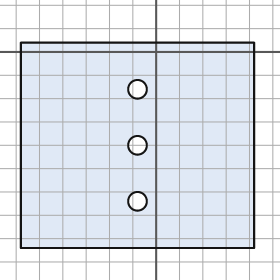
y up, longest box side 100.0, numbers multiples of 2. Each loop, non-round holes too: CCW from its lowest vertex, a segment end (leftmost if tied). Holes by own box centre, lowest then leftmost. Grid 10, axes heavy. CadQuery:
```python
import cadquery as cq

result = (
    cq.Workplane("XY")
    .moveTo(-58.0, -84.0)
    .lineTo(42.0, -84.0)
    .lineTo(42.0, 4.0)
    .lineTo(-58.0, 4.0)
    .close()
    .moveTo(-8.0, -64.0)
    .circle(4.0)
    .moveTo(-8.0, -40.0)
    .circle(4.0)
    .moveTo(-8.0, -16.0)
    .circle(4.0)
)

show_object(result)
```